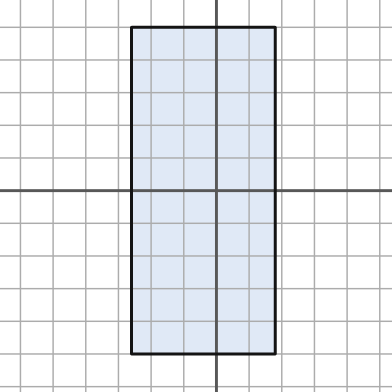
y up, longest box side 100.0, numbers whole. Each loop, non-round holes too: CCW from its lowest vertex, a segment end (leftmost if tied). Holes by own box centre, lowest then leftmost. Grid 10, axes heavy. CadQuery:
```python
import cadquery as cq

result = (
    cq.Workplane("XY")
    .moveTo(-26.0, -50.0)
    .lineTo(18.0, -50.0)
    .lineTo(18.0, 50.0)
    .lineTo(-26.0, 50.0)
    .close()
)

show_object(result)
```